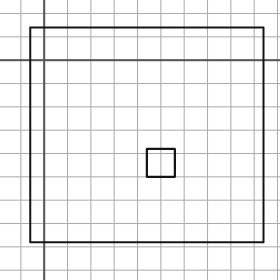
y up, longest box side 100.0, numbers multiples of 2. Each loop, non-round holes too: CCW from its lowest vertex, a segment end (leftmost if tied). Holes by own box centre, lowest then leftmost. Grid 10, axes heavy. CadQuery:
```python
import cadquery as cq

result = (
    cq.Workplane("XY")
    .moveTo(-6.0, -78.0)
    .lineTo(94.0, -78.0)
    .lineTo(94.0, 14.0)
    .lineTo(-6.0, 14.0)
    .close()
    .moveTo(44.0, -50.0)
    .lineTo(56.0, -50.0)
    .lineTo(56.0, -38.0)
    .lineTo(44.0, -38.0)
    .close()
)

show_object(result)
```